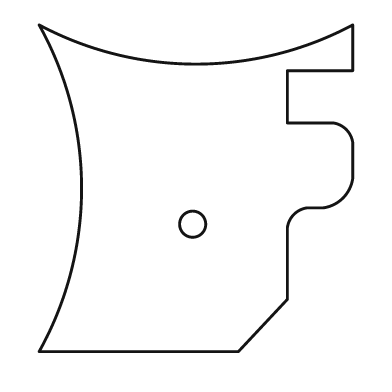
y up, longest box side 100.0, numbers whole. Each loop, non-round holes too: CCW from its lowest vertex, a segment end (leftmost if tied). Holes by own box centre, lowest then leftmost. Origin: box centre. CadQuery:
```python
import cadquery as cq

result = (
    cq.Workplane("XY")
    .moveTo(-48.0, -50.0)
    .lineTo(13.0, -50.0)
    .lineTo(28.0, -34.0)
    .lineTo(28.0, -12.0)
    .threePointArc((30.0, -8.0), (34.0, -6.0))
    .lineTo(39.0, -6.0)
    .threePointArc((45.0, -3.0), (48.0, 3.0))
    .lineTo(48.0, 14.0)
    .threePointArc((46.0, 18.0), (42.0, 20.0))
    .lineTo(28.0, 20.0)
    .lineTo(28.0, 36.0)
    .lineTo(48.0, 36.0)
    .lineTo(48.0, 50.0)
    .threePointArc((0.0, 38.0), (-48.0, 50.0))
    .threePointArc((-35.0, 0.0), (-48.0, -50.0))
    .close()
    .moveTo(-1.0, -11.0)
    .circle(4.0)
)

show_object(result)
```